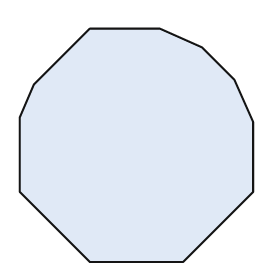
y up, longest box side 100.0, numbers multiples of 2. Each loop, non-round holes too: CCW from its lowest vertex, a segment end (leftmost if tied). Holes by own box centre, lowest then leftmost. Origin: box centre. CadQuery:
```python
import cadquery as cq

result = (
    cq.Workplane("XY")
    .moveTo(-20.0, -50.0)
    .lineTo(20.0, -50.0)
    .lineTo(50.0, -20.0)
    .lineTo(50.0, 10.0)
    .lineTo(42.0, 28.0)
    .lineTo(28.0, 42.0)
    .lineTo(10.0, 50.0)
    .lineTo(-20.0, 50.0)
    .lineTo(-44.0, 26.0)
    .lineTo(-50.0, 12.0)
    .lineTo(-50.0, -20.0)
    .close()
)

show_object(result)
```